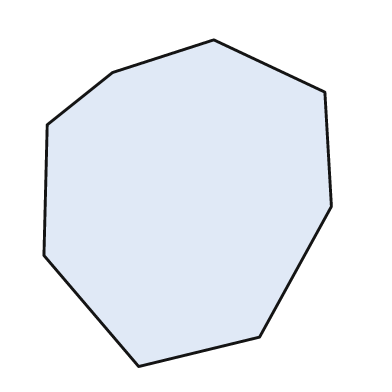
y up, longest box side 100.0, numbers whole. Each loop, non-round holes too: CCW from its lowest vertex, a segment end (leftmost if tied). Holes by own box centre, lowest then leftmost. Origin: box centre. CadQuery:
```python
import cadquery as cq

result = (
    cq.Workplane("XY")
    .moveTo(-15.0, -50.0)
    .lineTo(22.0, -41.0)
    .lineTo(44.0, -1.0)
    .lineTo(42.0, 34.0)
    .lineTo(8.0, 50.0)
    .lineTo(-23.0, 40.0)
    .lineTo(-43.0, 24.0)
    .lineTo(-44.0, -16.0)
    .close()
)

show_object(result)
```